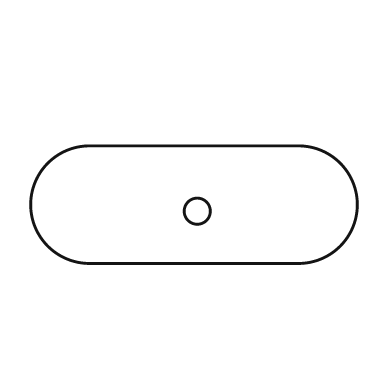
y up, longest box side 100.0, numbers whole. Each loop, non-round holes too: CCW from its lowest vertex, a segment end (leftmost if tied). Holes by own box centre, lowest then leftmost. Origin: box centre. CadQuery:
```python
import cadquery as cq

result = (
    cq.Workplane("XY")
    .moveTo(-32.0, -18.0)
    .lineTo(32.0, -18.0)
    .threePointArc((50.0, 0.0), (32.0, 18.0))
    .lineTo(-32.0, 18.0)
    .threePointArc((-50.0, 0.0), (-32.0, -18.0))
    .close()
    .moveTo(1.0, -2.0)
    .circle(4.0)
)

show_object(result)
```